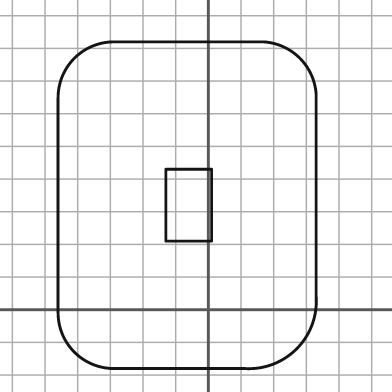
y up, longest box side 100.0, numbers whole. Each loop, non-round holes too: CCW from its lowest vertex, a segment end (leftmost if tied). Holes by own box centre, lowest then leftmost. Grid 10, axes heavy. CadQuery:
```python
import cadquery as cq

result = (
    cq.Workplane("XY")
    .moveTo(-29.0, -18.0)
    .lineTo(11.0, -18.0)
    .threePointArc((27.0, -12.0), (33.0, 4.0))
    .lineTo(33.0, 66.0)
    .threePointArc((28.0, 77.0), (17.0, 82.0))
    .lineTo(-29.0, 82.0)
    .threePointArc((-41.0, 77.0), (-46.0, 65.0))
    .lineTo(-46.0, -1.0)
    .threePointArc((-41.0, -13.0), (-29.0, -18.0))
    .close()
    .moveTo(-13.0, 21.0)
    .lineTo(1.0, 21.0)
    .lineTo(1.0, 43.0)
    .lineTo(-13.0, 43.0)
    .close()
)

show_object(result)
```